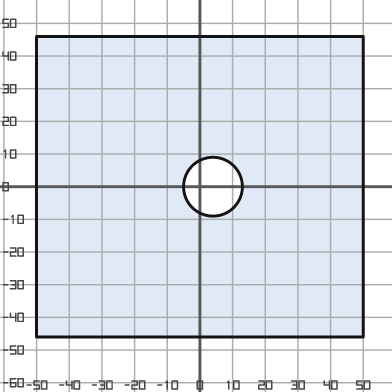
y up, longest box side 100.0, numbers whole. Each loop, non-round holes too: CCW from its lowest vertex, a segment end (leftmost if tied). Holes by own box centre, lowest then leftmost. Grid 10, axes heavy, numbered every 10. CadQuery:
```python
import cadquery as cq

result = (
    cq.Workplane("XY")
    .moveTo(-50.0, -46.0)
    .lineTo(50.0, -46.0)
    .lineTo(50.0, 46.0)
    .lineTo(-50.0, 46.0)
    .close()
    .moveTo(4.0, 0.0)
    .circle(9.0)
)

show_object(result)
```